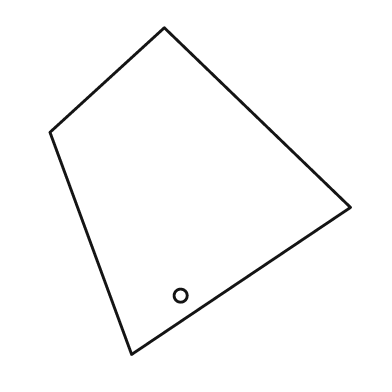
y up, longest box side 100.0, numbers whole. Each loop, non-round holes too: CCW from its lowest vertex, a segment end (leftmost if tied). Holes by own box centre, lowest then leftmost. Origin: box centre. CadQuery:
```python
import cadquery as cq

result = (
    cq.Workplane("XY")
    .moveTo(-21.0, -50.0)
    .lineTo(46.0, -5.0)
    .lineTo(-11.0, 50.0)
    .lineTo(-46.0, 18.0)
    .close()
    .moveTo(-6.0, -32.0)
    .circle(2.0)
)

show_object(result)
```